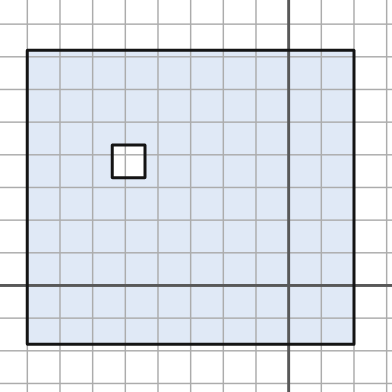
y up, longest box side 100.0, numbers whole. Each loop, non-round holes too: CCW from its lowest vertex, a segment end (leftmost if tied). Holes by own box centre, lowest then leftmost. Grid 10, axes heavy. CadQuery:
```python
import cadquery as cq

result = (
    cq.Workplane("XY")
    .moveTo(-80.0, -18.0)
    .lineTo(20.0, -18.0)
    .lineTo(20.0, 72.0)
    .lineTo(-80.0, 72.0)
    .close()
    .moveTo(-54.0, 33.0)
    .lineTo(-44.0, 33.0)
    .lineTo(-44.0, 43.0)
    .lineTo(-54.0, 43.0)
    .close()
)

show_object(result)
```